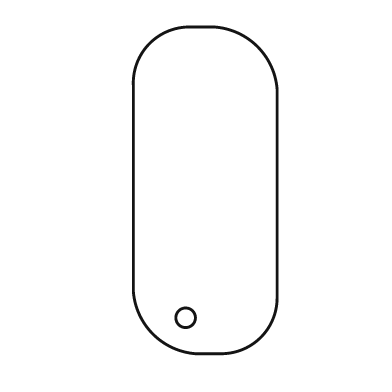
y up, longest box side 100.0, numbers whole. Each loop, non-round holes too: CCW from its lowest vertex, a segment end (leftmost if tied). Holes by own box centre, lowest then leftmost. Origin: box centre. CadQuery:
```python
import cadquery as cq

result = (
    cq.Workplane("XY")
    .moveTo(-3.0, -50.0)
    .lineTo(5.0, -50.0)
    .threePointArc((17.0, -45.0), (22.0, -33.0))
    .lineTo(22.0, 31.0)
    .threePointArc((16.0, 44.0), (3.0, 50.0))
    .lineTo(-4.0, 50.0)
    .threePointArc((-17.0, 45.0), (-22.0, 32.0))
    .lineTo(-22.0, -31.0)
    .threePointArc((-16.0, -44.0), (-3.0, -50.0))
    .close()
    .moveTo(-6.0, -39.0)
    .circle(3.0)
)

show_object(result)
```